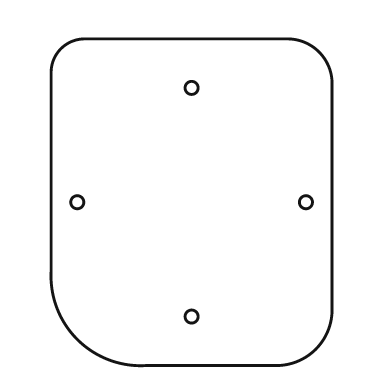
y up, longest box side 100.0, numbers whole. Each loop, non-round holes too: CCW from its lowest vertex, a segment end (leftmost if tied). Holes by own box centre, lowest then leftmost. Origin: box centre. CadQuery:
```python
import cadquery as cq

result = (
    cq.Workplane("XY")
    .moveTo(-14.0, -50.0)
    .lineTo(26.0, -50.0)
    .threePointArc((38.0, -45.0), (43.0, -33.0))
    .lineTo(43.0, 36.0)
    .threePointArc((39.0, 46.0), (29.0, 50.0))
    .lineTo(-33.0, 50.0)
    .threePointArc((-40.0, 47.0), (-43.0, 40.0))
    .lineTo(-43.0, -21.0)
    .threePointArc((-35.0, -42.0), (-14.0, -50.0))
    .close()
    .moveTo(0.0, -35.0)
    .circle(2.0)
    .moveTo(-35.0, 0.0)
    .circle(2.0)
    .moveTo(35.0, 0.0)
    .circle(2.0)
    .moveTo(0.0, 35.0)
    .circle(2.0)
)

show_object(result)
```